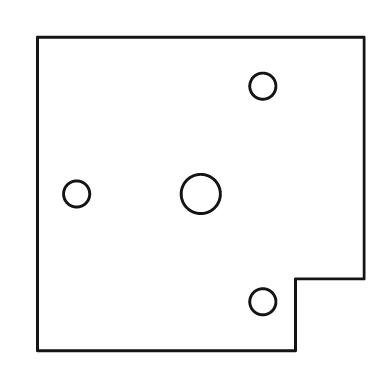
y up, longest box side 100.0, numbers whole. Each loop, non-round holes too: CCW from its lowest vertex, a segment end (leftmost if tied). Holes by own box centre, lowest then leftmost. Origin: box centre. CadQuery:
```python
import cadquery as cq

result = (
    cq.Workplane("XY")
    .moveTo(-50.0, -48.0)
    .lineTo(29.0, -48.0)
    .lineTo(29.0, -26.0)
    .lineTo(50.0, -26.0)
    .lineTo(50.0, 48.0)
    .lineTo(-50.0, 48.0)
    .close()
    .moveTo(19.0, -33.0)
    .circle(4.0)
    .moveTo(-38.0, 0.0)
    .circle(4.0)
    .moveTo(0.0, 0.0)
    .circle(6.0)
    .moveTo(19.0, 33.0)
    .circle(4.0)
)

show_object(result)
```